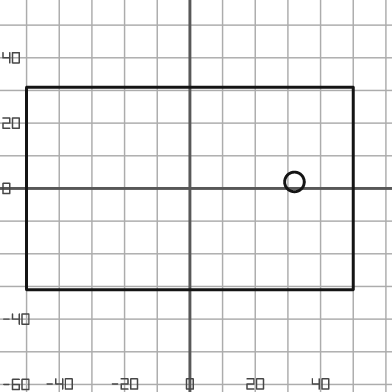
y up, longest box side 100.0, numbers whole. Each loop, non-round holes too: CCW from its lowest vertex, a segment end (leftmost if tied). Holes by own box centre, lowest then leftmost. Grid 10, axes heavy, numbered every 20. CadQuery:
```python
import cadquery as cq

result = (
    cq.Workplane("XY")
    .moveTo(-50.0, -31.0)
    .lineTo(50.0, -31.0)
    .lineTo(50.0, 31.0)
    .lineTo(-50.0, 31.0)
    .close()
    .moveTo(32.0, 2.0)
    .circle(3.0)
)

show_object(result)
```